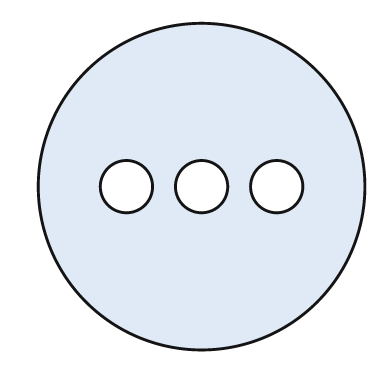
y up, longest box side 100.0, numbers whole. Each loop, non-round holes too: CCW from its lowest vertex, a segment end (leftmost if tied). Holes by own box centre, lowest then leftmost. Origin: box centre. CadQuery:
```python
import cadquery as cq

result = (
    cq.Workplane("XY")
    .moveTo(0.0, 0.0)
    .circle(50.0)
    .moveTo(-23.0, 0.0)
    .circle(8.0)
    .moveTo(0.0, 0.0)
    .circle(8.0)
    .moveTo(23.0, 0.0)
    .circle(8.0)
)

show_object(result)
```